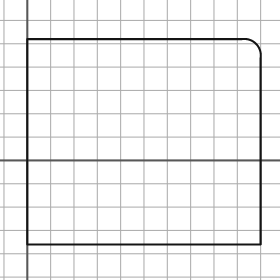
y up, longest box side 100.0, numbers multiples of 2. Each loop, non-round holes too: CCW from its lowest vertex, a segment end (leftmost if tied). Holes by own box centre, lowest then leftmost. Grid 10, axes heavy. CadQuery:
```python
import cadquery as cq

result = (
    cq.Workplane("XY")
    .moveTo(0.0, -36.0)
    .lineTo(100.0, -36.0)
    .lineTo(100.0, 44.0)
    .threePointArc((98.0, 50.0), (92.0, 52.0))
    .lineTo(0.0, 52.0)
    .close()
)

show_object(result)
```